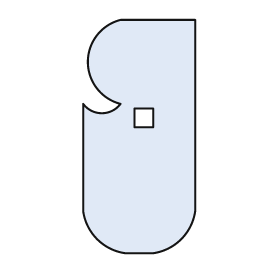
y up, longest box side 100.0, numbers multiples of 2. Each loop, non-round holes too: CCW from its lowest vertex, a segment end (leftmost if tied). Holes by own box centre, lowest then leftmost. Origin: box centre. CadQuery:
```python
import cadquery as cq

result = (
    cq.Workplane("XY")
    .moveTo(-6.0, -50.0)
    .lineTo(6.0, -50.0)
    .threePointArc((18.0, -44.0), (24.0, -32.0))
    .lineTo(24.0, 50.0)
    .lineTo(-8.0, 50.0)
    .threePointArc((-22.0, 32.0), (-8.0, 14.0))
    .threePointArc((-16.0, 10.0), (-24.0, 14.0))
    .lineTo(-24.0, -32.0)
    .threePointArc((-18.0, -44.0), (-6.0, -50.0))
    .close()
    .moveTo(-2.0, 4.0)
    .lineTo(6.0, 4.0)
    .lineTo(6.0, 12.0)
    .lineTo(-2.0, 12.0)
    .close()
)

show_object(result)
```